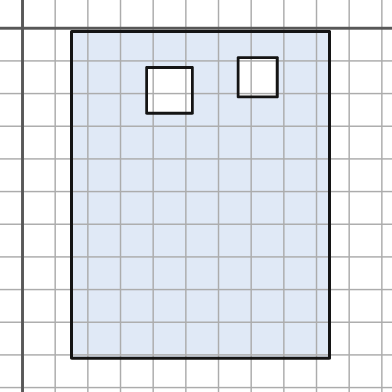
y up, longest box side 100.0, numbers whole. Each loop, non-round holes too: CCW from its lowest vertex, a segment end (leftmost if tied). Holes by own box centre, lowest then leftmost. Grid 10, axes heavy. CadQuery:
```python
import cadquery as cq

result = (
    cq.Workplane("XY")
    .moveTo(15.0, -101.0)
    .lineTo(94.0, -101.0)
    .lineTo(94.0, -1.0)
    .lineTo(15.0, -1.0)
    .close()
    .moveTo(38.0, -26.0)
    .lineTo(52.0, -26.0)
    .lineTo(52.0, -12.0)
    .lineTo(38.0, -12.0)
    .close()
    .moveTo(66.0, -21.0)
    .lineTo(78.0, -21.0)
    .lineTo(78.0, -9.0)
    .lineTo(66.0, -9.0)
    .close()
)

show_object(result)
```